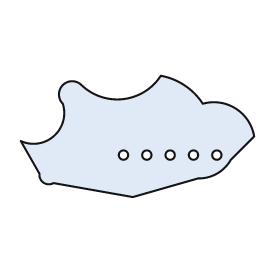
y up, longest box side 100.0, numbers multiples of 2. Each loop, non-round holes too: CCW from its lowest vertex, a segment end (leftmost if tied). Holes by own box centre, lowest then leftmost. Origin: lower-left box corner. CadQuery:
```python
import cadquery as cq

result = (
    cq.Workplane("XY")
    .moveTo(48.0, 0.0)
    .lineTo(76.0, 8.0)
    .threePointArc((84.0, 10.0), (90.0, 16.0))
    .lineTo(100.0, 26.0)
    .threePointArc((92.0, 38.0), (78.0, 40.0))
    .threePointArc((70.0, 48.0), (60.0, 52.0))
    .threePointArc((44.0, 42.0), (26.0, 48.0))
    .threePointArc((18.0, 48.0), (18.0, 40.0))
    .threePointArc((14.0, 26.0), (0.0, 24.0))
    .lineTo(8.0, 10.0)
    .threePointArc((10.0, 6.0), (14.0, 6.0))
    .close()
    .moveTo(44.0, 18.0)
    .circle(2.0)
    .moveTo(54.0, 18.0)
    .circle(2.0)
    .moveTo(64.0, 18.0)
    .circle(2.0)
    .moveTo(74.0, 18.0)
    .circle(2.0)
    .moveTo(84.0, 18.0)
    .circle(2.0)
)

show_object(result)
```